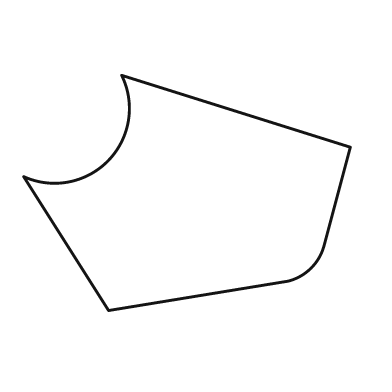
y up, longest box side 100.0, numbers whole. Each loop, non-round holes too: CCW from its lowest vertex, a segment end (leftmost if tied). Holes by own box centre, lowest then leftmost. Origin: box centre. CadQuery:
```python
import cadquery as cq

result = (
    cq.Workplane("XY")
    .moveTo(-24.0, -36.0)
    .lineTo(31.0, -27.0)
    .threePointArc((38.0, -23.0), (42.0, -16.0))
    .lineTo(50.0, 14.0)
    .lineTo(-20.0, 36.0)
    .threePointArc((-24.0, 10.0), (-50.0, 5.0))
    .close()
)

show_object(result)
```